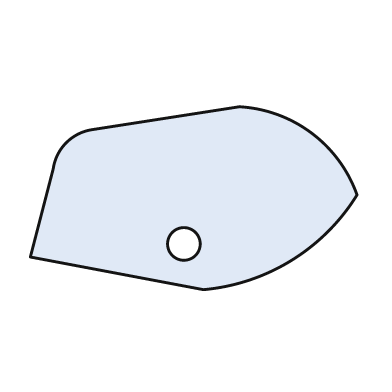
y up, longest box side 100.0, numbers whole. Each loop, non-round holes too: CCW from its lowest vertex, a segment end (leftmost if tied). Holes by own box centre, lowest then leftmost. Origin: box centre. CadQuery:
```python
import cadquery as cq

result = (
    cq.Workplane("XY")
    .moveTo(3.0, -28.0)
    .threePointArc((30.0, -19.0), (50.0, 1.0))
    .threePointArc((36.0, 20.0), (14.0, 28.0))
    .lineTo(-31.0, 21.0)
    .threePointArc((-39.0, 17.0), (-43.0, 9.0))
    .lineTo(-50.0, -18.0)
    .close()
    .moveTo(-3.0, -14.0)
    .circle(5.0)
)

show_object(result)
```